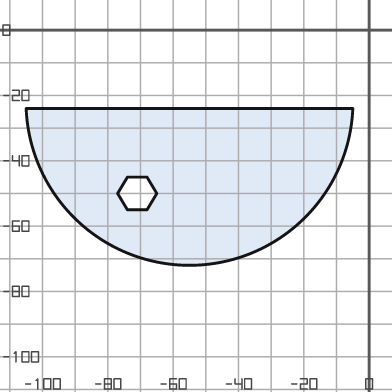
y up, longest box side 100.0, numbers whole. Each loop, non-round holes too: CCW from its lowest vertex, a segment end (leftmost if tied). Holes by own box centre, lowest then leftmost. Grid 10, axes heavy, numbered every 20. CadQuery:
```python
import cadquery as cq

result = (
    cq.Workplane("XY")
    .moveTo(-105.0, -24.0)
    .threePointArc((-55.0, -72.0), (-5.0, -24.0))
    .close()
    .moveTo(-74.0, -55.0)
    .lineTo(-68.0, -55.0)
    .lineTo(-65.0, -50.0)
    .lineTo(-68.0, -45.0)
    .lineTo(-74.0, -45.0)
    .lineTo(-77.0, -50.0)
    .close()
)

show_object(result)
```